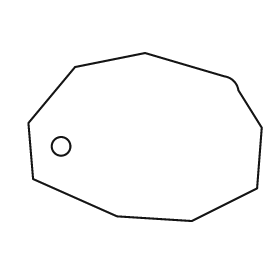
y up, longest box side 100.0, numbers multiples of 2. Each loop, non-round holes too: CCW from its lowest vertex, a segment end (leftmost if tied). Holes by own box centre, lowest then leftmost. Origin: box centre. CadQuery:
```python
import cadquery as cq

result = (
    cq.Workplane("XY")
    .moveTo(20.0, -36.0)
    .lineTo(48.0, -22.0)
    .lineTo(50.0, 4.0)
    .lineTo(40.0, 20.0)
    .threePointArc((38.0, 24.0), (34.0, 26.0))
    .lineTo(0.0, 36.0)
    .lineTo(-30.0, 30.0)
    .lineTo(-50.0, 6.0)
    .lineTo(-48.0, -18.0)
    .lineTo(-12.0, -34.0)
    .close()
    .moveTo(-36.0, -4.0)
    .circle(4.0)
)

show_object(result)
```